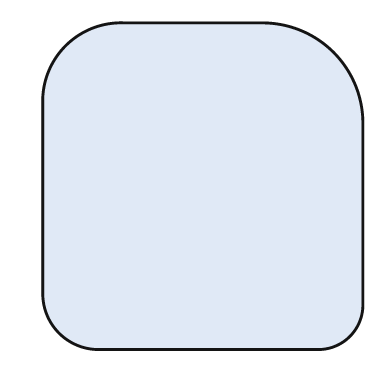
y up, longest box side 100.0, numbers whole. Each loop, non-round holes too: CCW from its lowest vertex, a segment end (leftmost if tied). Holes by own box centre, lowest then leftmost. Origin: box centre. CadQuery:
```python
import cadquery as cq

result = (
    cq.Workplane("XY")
    .moveTo(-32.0, -50.0)
    .lineTo(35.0, -50.0)
    .threePointArc((45.0, -46.0), (49.0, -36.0))
    .lineTo(49.0, 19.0)
    .threePointArc((40.0, 41.0), (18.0, 50.0))
    .lineTo(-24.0, 50.0)
    .threePointArc((-42.0, 43.0), (-49.0, 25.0))
    .lineTo(-49.0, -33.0)
    .threePointArc((-44.0, -45.0), (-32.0, -50.0))
    .close()
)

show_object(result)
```